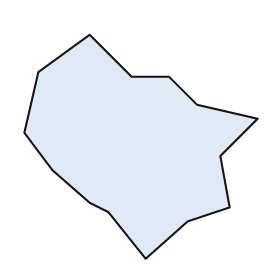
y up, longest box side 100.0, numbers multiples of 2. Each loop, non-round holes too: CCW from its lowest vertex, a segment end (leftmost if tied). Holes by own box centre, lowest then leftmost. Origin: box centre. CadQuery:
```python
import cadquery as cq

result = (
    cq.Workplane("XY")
    .moveTo(2.0, -48.0)
    .lineTo(20.0, -32.0)
    .lineTo(38.0, -26.0)
    .lineTo(34.0, -4.0)
    .lineTo(50.0, 12.0)
    .lineTo(24.0, 18.0)
    .lineTo(12.0, 30.0)
    .lineTo(-4.0, 30.0)
    .lineTo(-22.0, 48.0)
    .lineTo(-44.0, 32.0)
    .lineTo(-50.0, 6.0)
    .lineTo(-38.0, -10.0)
    .lineTo(-22.0, -24.0)
    .lineTo(-14.0, -28.0)
    .close()
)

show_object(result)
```